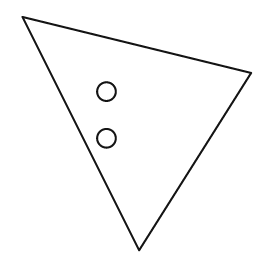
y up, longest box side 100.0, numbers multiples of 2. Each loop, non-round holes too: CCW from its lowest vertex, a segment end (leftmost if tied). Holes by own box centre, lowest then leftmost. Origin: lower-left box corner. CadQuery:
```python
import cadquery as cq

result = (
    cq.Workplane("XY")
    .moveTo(50.0, 0.0)
    .lineTo(98.0, 76.0)
    .lineTo(0.0, 100.0)
    .close()
    .moveTo(36.0, 48.0)
    .circle(4.0)
    .moveTo(36.0, 68.0)
    .circle(4.0)
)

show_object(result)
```